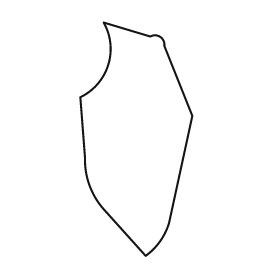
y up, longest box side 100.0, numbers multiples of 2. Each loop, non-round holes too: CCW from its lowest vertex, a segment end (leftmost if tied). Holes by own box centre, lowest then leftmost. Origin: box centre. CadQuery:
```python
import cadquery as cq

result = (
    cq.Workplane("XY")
    .moveTo(4.0, -50.0)
    .threePointArc((10.0, -44.0), (14.0, -36.0))
    .lineTo(24.0, 10.0)
    .lineTo(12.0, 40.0)
    .threePointArc((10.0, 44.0), (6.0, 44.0))
    .lineTo(-14.0, 50.0)
    .threePointArc((-12.0, 32.0), (-24.0, 18.0))
    .lineTo(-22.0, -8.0)
    .threePointArc((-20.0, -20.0), (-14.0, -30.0))
    .close()
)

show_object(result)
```